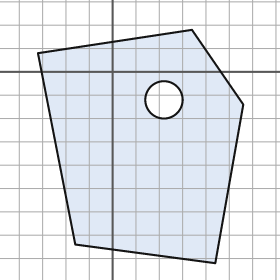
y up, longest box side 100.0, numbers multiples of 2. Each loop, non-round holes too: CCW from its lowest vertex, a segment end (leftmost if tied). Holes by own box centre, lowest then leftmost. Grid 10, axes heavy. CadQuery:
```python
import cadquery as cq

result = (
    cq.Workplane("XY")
    .moveTo(44.0, -82.0)
    .lineTo(56.0, -14.0)
    .lineTo(34.0, 18.0)
    .lineTo(-32.0, 8.0)
    .lineTo(-16.0, -74.0)
    .close()
    .moveTo(22.0, -12.0)
    .circle(8.0)
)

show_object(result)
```